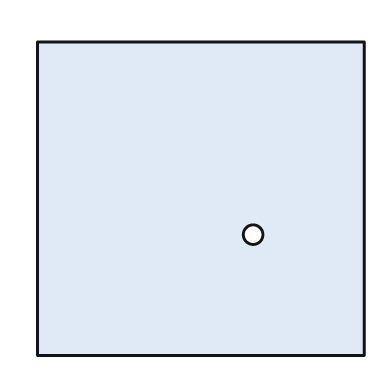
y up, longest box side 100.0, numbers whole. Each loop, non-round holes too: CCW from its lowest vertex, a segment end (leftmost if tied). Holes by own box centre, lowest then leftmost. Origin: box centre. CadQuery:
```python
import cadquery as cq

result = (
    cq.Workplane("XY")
    .moveTo(-50.0, -48.0)
    .lineTo(50.0, -48.0)
    .lineTo(50.0, 48.0)
    .lineTo(-50.0, 48.0)
    .close()
    .moveTo(16.0, -11.0)
    .circle(3.0)
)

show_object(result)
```